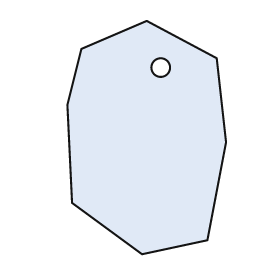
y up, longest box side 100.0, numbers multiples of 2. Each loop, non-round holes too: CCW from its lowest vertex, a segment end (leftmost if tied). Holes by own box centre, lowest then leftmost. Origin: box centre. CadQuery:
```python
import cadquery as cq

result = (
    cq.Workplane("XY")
    .moveTo(-2.0, -50.0)
    .lineTo(26.0, -44.0)
    .lineTo(34.0, -2.0)
    .lineTo(30.0, 34.0)
    .lineTo(0.0, 50.0)
    .lineTo(-28.0, 38.0)
    .lineTo(-34.0, 14.0)
    .lineTo(-32.0, -28.0)
    .close()
    .moveTo(6.0, 30.0)
    .circle(4.0)
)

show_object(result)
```